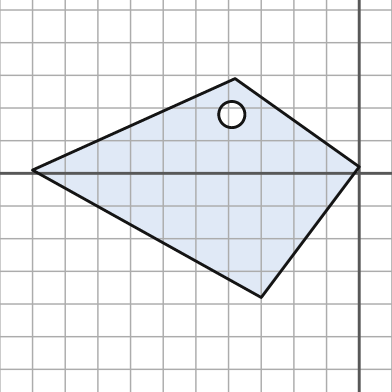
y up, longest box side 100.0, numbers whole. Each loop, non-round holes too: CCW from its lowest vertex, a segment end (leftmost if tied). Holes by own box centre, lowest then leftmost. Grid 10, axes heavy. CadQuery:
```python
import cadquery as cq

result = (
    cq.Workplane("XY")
    .moveTo(-30.0, -38.0)
    .lineTo(0.0, 2.0)
    .lineTo(-38.0, 29.0)
    .lineTo(-100.0, 1.0)
    .close()
    .moveTo(-39.0, 18.0)
    .circle(4.0)
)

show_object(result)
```